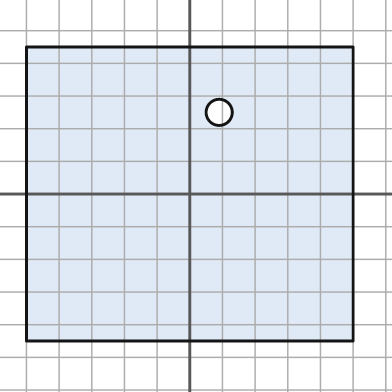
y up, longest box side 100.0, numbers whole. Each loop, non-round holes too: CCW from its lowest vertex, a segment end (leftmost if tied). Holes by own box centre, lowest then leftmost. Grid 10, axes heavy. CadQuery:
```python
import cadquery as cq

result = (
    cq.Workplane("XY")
    .moveTo(-50.0, -45.0)
    .lineTo(50.0, -45.0)
    .lineTo(50.0, 45.0)
    .lineTo(-50.0, 45.0)
    .close()
    .moveTo(9.0, 25.0)
    .circle(4.0)
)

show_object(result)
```